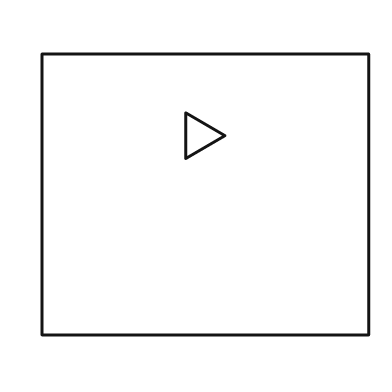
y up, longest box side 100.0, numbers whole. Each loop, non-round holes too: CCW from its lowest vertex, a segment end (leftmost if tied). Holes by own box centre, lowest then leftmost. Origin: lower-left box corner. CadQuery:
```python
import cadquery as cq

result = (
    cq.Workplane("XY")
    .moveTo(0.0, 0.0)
    .lineTo(100.0, 0.0)
    .lineTo(100.0, 86.0)
    .lineTo(0.0, 86.0)
    .close()
    .moveTo(44.0, 54.0)
    .lineTo(56.0, 61.0)
    .lineTo(44.0, 68.0)
    .close()
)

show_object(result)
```